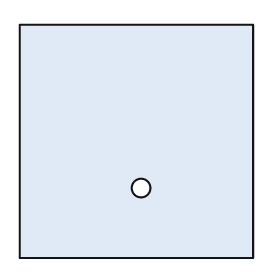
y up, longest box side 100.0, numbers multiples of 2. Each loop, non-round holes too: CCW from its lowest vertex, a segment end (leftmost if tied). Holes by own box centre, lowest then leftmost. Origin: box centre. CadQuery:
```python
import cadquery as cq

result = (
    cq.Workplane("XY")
    .moveTo(-50.0, -50.0)
    .lineTo(50.0, -50.0)
    .lineTo(50.0, 50.0)
    .lineTo(-50.0, 50.0)
    .close()
    .moveTo(2.0, -20.0)
    .circle(4.0)
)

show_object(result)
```